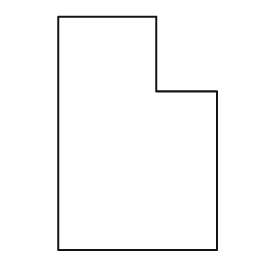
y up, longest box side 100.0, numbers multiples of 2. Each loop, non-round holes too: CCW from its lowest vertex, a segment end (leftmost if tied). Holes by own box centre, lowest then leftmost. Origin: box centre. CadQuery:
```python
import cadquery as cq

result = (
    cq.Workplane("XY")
    .moveTo(-34.0, -50.0)
    .lineTo(34.0, -50.0)
    .lineTo(34.0, 18.0)
    .lineTo(8.0, 18.0)
    .lineTo(8.0, 50.0)
    .lineTo(-34.0, 50.0)
    .close()
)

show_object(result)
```